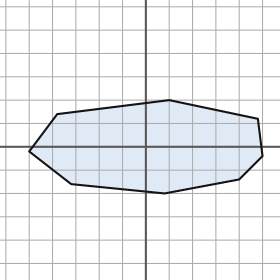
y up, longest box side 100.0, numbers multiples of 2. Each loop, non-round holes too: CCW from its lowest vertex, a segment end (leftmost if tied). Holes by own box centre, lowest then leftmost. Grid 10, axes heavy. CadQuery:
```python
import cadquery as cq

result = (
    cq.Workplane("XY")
    .moveTo(8.0, -20.0)
    .lineTo(40.0, -14.0)
    .lineTo(50.0, -4.0)
    .lineTo(48.0, 12.0)
    .lineTo(10.0, 20.0)
    .lineTo(-38.0, 14.0)
    .lineTo(-50.0, -2.0)
    .lineTo(-32.0, -16.0)
    .close()
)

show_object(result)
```